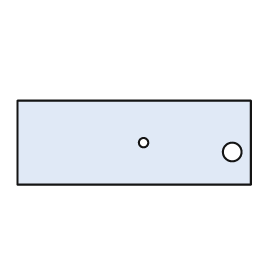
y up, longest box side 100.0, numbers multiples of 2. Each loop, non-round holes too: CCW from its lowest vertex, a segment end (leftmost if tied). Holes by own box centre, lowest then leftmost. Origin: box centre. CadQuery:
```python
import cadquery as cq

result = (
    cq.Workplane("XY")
    .moveTo(-50.0, -18.0)
    .lineTo(50.0, -18.0)
    .lineTo(50.0, 18.0)
    .lineTo(-50.0, 18.0)
    .close()
    .moveTo(42.0, -4.0)
    .circle(4.0)
    .moveTo(4.0, 0.0)
    .circle(2.0)
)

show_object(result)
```